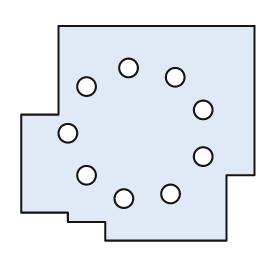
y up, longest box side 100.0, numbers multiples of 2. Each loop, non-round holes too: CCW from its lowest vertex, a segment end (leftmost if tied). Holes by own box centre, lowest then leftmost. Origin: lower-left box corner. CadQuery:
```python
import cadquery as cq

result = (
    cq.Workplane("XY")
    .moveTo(36.0, 0.0)
    .lineTo(88.0, 0.0)
    .lineTo(88.0, 28.0)
    .lineTo(100.0, 28.0)
    .lineTo(100.0, 92.0)
    .lineTo(16.0, 92.0)
    .lineTo(16.0, 54.0)
    .lineTo(0.0, 54.0)
    .lineTo(0.0, 12.0)
    .lineTo(20.0, 12.0)
    .lineTo(20.0, 8.0)
    .lineTo(36.0, 8.0)
    .close()
    .moveTo(44.0, 18.0)
    .circle(4.0)
    .moveTo(64.0, 20.0)
    .circle(4.0)
    .moveTo(28.0, 28.0)
    .circle(4.0)
    .moveTo(78.0, 36.0)
    .circle(4.0)
    .moveTo(20.0, 46.0)
    .circle(4.0)
    .moveTo(78.0, 56.0)
    .circle(4.0)
    .moveTo(28.0, 66.0)
    .circle(4.0)
    .moveTo(66.0, 70.0)
    .circle(4.0)
    .moveTo(46.0, 74.0)
    .circle(4.0)
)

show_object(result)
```